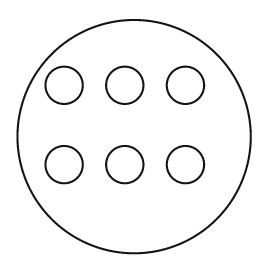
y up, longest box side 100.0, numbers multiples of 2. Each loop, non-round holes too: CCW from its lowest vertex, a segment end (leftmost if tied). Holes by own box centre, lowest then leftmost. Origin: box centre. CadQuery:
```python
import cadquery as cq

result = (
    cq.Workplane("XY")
    .moveTo(0.0, 0.0)
    .circle(50.0)
    .moveTo(-30.0, -12.0)
    .circle(8.0)
    .moveTo(-4.0, -12.0)
    .circle(8.0)
    .moveTo(22.0, -12.0)
    .circle(8.0)
    .moveTo(-30.0, 22.0)
    .circle(8.0)
    .moveTo(-4.0, 22.0)
    .circle(8.0)
    .moveTo(22.0, 22.0)
    .circle(8.0)
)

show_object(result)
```